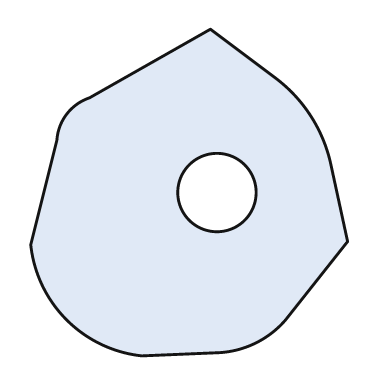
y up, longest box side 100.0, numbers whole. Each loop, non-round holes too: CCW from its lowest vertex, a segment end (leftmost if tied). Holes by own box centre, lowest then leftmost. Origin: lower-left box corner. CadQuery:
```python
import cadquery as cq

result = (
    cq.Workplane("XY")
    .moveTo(34.0, 0.0)
    .lineTo(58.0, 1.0)
    .threePointArc((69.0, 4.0), (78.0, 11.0))
    .lineTo(97.0, 35.0)
    .lineTo(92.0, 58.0)
    .threePointArc((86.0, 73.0), (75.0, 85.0))
    .lineTo(55.0, 100.0)
    .lineTo(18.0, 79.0)
    .threePointArc((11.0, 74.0), (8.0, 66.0))
    .lineTo(0.0, 34.0)
    .threePointArc((11.0, 11.0), (34.0, 0.0))
    .close()
    .moveTo(57.0, 50.0)
    .circle(12.0)
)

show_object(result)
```